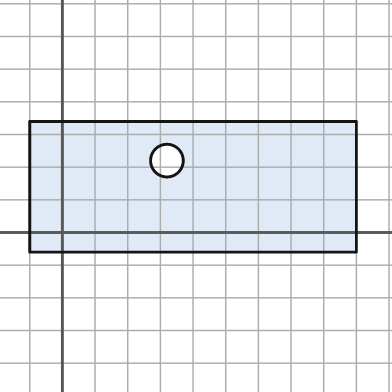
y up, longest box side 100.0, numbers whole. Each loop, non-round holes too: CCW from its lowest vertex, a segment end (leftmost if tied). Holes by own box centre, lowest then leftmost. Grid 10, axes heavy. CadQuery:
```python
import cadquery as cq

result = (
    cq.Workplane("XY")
    .moveTo(-10.0, -6.0)
    .lineTo(90.0, -6.0)
    .lineTo(90.0, 34.0)
    .lineTo(-10.0, 34.0)
    .close()
    .moveTo(32.0, 22.0)
    .circle(5.0)
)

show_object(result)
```